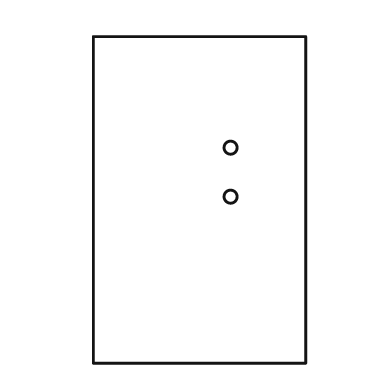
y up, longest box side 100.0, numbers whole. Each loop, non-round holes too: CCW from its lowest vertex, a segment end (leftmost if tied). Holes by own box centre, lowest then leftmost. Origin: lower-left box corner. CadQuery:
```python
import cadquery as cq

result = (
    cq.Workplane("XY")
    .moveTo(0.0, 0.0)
    .lineTo(65.0, 0.0)
    .lineTo(65.0, 100.0)
    .lineTo(0.0, 100.0)
    .close()
    .moveTo(42.0, 51.0)
    .circle(2.0)
    .moveTo(42.0, 66.0)
    .circle(2.0)
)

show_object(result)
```